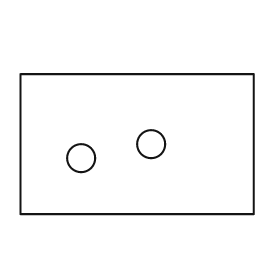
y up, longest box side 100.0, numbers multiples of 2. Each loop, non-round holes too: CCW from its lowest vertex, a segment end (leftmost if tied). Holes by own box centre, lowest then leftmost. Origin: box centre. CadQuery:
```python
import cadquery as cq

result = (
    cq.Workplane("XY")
    .moveTo(-50.0, -30.0)
    .lineTo(50.0, -30.0)
    .lineTo(50.0, 30.0)
    .lineTo(-50.0, 30.0)
    .close()
    .moveTo(-24.0, -6.0)
    .circle(6.0)
    .moveTo(6.0, 0.0)
    .circle(6.0)
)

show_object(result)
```